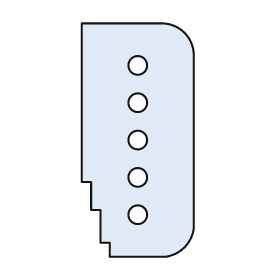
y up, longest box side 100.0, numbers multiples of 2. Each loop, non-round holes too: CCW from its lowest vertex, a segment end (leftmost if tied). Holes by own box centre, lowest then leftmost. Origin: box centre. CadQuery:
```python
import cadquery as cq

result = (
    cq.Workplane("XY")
    .moveTo(-12.0, -50.0)
    .lineTo(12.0, -50.0)
    .threePointArc((20.0, -46.0), (24.0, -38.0))
    .lineTo(24.0, 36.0)
    .threePointArc((20.0, 46.0), (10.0, 50.0))
    .lineTo(-24.0, 50.0)
    .lineTo(-24.0, -18.0)
    .lineTo(-20.0, -18.0)
    .lineTo(-20.0, -30.0)
    .lineTo(-16.0, -30.0)
    .lineTo(-16.0, -44.0)
    .lineTo(-12.0, -44.0)
    .close()
    .moveTo(0.0, -32.0)
    .circle(4.0)
    .moveTo(0.0, -16.0)
    .circle(4.0)
    .moveTo(0.0, 0.0)
    .circle(4.0)
    .moveTo(0.0, 16.0)
    .circle(4.0)
    .moveTo(0.0, 32.0)
    .circle(4.0)
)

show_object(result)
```